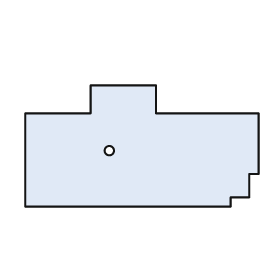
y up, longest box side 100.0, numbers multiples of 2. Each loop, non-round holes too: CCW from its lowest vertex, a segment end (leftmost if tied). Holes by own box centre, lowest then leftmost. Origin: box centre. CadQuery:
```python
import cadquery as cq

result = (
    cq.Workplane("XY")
    .moveTo(-50.0, -26.0)
    .lineTo(38.0, -26.0)
    .lineTo(38.0, -22.0)
    .lineTo(46.0, -22.0)
    .lineTo(46.0, -12.0)
    .lineTo(50.0, -12.0)
    .lineTo(50.0, 14.0)
    .lineTo(6.0, 14.0)
    .lineTo(6.0, 26.0)
    .lineTo(-22.0, 26.0)
    .lineTo(-22.0, 14.0)
    .lineTo(-50.0, 14.0)
    .close()
    .moveTo(-14.0, -2.0)
    .circle(2.0)
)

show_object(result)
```